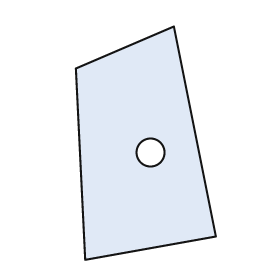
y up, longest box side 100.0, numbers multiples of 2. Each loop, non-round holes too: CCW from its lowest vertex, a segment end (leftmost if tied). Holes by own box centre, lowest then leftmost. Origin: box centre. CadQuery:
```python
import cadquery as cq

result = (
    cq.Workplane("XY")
    .moveTo(-26.0, -50.0)
    .lineTo(30.0, -40.0)
    .lineTo(12.0, 50.0)
    .lineTo(-30.0, 32.0)
    .close()
    .moveTo(2.0, -4.0)
    .circle(6.0)
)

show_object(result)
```